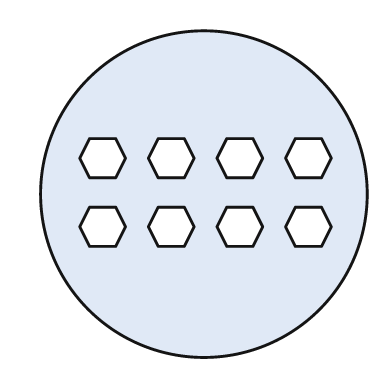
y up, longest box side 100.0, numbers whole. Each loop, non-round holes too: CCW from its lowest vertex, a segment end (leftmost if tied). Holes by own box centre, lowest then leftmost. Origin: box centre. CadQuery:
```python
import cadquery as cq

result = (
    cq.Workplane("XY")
    .moveTo(0.0, 0.0)
    .circle(50.0)
    .moveTo(-35.0, -16.0)
    .lineTo(-27.0, -16.0)
    .lineTo(-24.0, -10.0)
    .lineTo(-27.0, -4.0)
    .lineTo(-35.0, -4.0)
    .lineTo(-38.0, -10.0)
    .close()
    .moveTo(-14.0, -16.0)
    .lineTo(-6.0, -16.0)
    .lineTo(-3.0, -10.0)
    .lineTo(-6.0, -4.0)
    .lineTo(-14.0, -4.0)
    .lineTo(-17.0, -10.0)
    .close()
    .moveTo(7.0, -16.0)
    .lineTo(15.0, -16.0)
    .lineTo(18.0, -10.0)
    .lineTo(15.0, -4.0)
    .lineTo(7.0, -4.0)
    .lineTo(4.0, -10.0)
    .close()
    .moveTo(28.0, -16.0)
    .lineTo(36.0, -16.0)
    .lineTo(39.0, -10.0)
    .lineTo(36.0, -4.0)
    .lineTo(28.0, -4.0)
    .lineTo(25.0, -10.0)
    .close()
    .moveTo(-35.0, 5.0)
    .lineTo(-27.0, 5.0)
    .lineTo(-24.0, 11.0)
    .lineTo(-27.0, 17.0)
    .lineTo(-35.0, 17.0)
    .lineTo(-38.0, 11.0)
    .close()
    .moveTo(-14.0, 5.0)
    .lineTo(-6.0, 5.0)
    .lineTo(-3.0, 11.0)
    .lineTo(-6.0, 17.0)
    .lineTo(-14.0, 17.0)
    .lineTo(-17.0, 11.0)
    .close()
    .moveTo(7.0, 5.0)
    .lineTo(15.0, 5.0)
    .lineTo(18.0, 11.0)
    .lineTo(15.0, 17.0)
    .lineTo(7.0, 17.0)
    .lineTo(4.0, 11.0)
    .close()
    .moveTo(28.0, 5.0)
    .lineTo(36.0, 5.0)
    .lineTo(39.0, 11.0)
    .lineTo(36.0, 17.0)
    .lineTo(28.0, 17.0)
    .lineTo(25.0, 11.0)
    .close()
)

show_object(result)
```